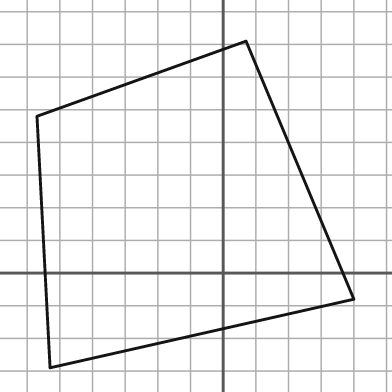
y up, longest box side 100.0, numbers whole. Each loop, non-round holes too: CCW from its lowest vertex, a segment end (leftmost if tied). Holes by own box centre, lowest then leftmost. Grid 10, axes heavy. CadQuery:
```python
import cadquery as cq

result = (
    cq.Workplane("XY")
    .moveTo(-53.0, -29.0)
    .lineTo(40.0, -8.0)
    .lineTo(7.0, 71.0)
    .lineTo(-57.0, 48.0)
    .close()
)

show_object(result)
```